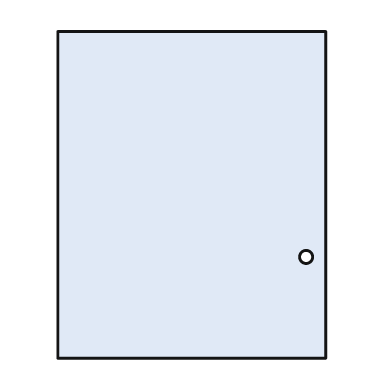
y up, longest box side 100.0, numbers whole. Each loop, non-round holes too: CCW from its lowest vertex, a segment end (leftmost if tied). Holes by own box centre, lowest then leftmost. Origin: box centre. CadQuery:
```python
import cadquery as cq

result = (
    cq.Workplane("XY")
    .moveTo(-41.0, -50.0)
    .lineTo(41.0, -50.0)
    .lineTo(41.0, 50.0)
    .lineTo(-41.0, 50.0)
    .close()
    .moveTo(35.0, -19.0)
    .circle(2.0)
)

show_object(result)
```